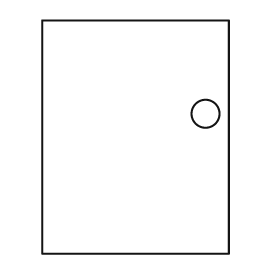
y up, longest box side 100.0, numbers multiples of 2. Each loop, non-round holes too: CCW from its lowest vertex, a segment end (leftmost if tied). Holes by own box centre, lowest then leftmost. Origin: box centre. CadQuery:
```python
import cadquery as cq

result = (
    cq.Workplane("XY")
    .moveTo(-40.0, -50.0)
    .lineTo(40.0, -50.0)
    .lineTo(40.0, 50.0)
    .lineTo(-40.0, 50.0)
    .close()
    .moveTo(30.0, 10.0)
    .circle(6.0)
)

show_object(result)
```